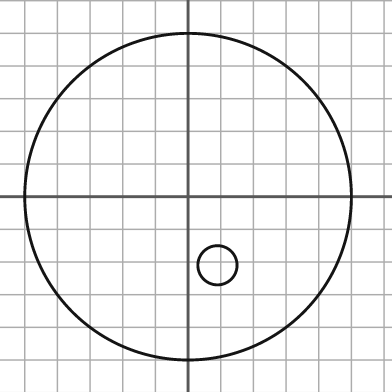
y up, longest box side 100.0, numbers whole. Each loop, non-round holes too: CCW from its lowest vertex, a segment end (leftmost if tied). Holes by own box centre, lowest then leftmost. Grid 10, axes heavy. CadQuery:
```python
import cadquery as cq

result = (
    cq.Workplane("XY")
    .moveTo(0.0, 0.0)
    .circle(50.0)
    .moveTo(9.0, -21.0)
    .circle(6.0)
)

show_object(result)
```